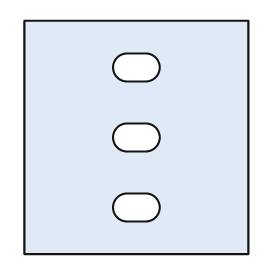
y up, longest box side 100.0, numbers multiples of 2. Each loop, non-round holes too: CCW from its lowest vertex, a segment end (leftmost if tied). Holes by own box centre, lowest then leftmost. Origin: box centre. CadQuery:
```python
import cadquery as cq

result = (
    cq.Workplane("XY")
    .moveTo(-48.0, -50.0)
    .lineTo(48.0, -50.0)
    .lineTo(48.0, 50.0)
    .lineTo(-48.0, 50.0)
    .close()
    .moveTo(-4.0, -36.0)
    .lineTo(4.0, -36.0)
    .threePointArc((10.0, -30.0), (4.0, -24.0))
    .lineTo(-4.0, -24.0)
    .threePointArc((-10.0, -30.0), (-4.0, -36.0))
    .close()
    .moveTo(-4.0, -6.0)
    .lineTo(4.0, -6.0)
    .threePointArc((10.0, 0.0), (4.0, 6.0))
    .lineTo(-4.0, 6.0)
    .threePointArc((-10.0, 0.0), (-4.0, -6.0))
    .close()
    .moveTo(-4.0, 24.0)
    .lineTo(4.0, 24.0)
    .threePointArc((10.0, 30.0), (4.0, 36.0))
    .lineTo(-4.0, 36.0)
    .threePointArc((-10.0, 30.0), (-4.0, 24.0))
    .close()
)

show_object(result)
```